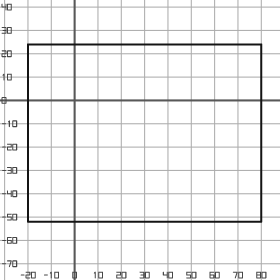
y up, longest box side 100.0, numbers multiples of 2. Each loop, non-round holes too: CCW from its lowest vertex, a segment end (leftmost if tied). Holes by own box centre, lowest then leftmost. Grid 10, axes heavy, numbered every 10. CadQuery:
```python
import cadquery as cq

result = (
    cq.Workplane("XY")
    .moveTo(-20.0, -52.0)
    .lineTo(80.0, -52.0)
    .lineTo(80.0, 24.0)
    .lineTo(-20.0, 24.0)
    .close()
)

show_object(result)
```